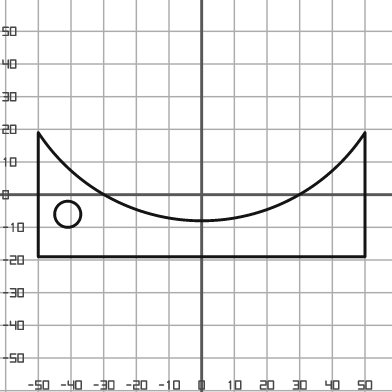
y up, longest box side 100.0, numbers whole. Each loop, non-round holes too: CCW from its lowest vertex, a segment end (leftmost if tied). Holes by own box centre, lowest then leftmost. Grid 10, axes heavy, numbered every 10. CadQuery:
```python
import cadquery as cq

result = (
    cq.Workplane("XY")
    .moveTo(-50.0, -19.0)
    .lineTo(50.0, -19.0)
    .lineTo(50.0, 19.0)
    .threePointArc((0.0, -8.0), (-50.0, 19.0))
    .close()
    .moveTo(-41.0, -6.0)
    .circle(4.0)
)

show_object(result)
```